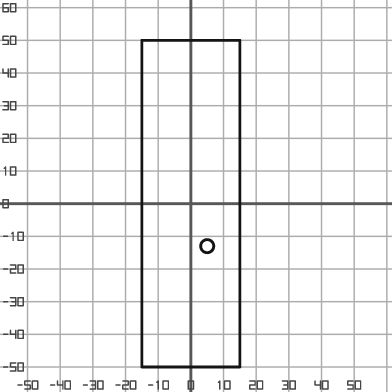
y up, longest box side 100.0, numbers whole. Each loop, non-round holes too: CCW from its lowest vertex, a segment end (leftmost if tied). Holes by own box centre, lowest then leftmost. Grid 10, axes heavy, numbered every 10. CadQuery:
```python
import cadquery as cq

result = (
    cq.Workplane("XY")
    .moveTo(-15.0, -50.0)
    .lineTo(15.0, -50.0)
    .lineTo(15.0, 50.0)
    .lineTo(-15.0, 50.0)
    .close()
    .moveTo(5.0, -13.0)
    .circle(2.0)
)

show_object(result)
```